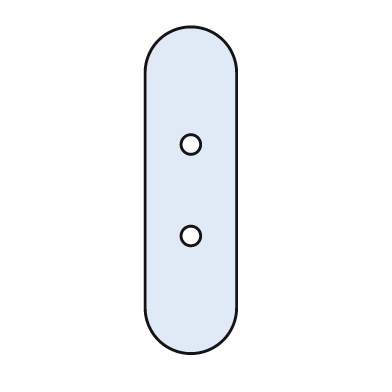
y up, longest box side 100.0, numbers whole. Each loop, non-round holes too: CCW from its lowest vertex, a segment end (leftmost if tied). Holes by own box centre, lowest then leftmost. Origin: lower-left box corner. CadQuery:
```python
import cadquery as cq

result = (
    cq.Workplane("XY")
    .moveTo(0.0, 14.0)
    .threePointArc((14.0, 0.0), (28.0, 14.0))
    .lineTo(28.0, 86.0)
    .threePointArc((14.0, 100.0), (0.0, 86.0))
    .close()
    .moveTo(14.0, 36.0)
    .circle(3.0)
    .moveTo(14.0, 64.0)
    .circle(3.0)
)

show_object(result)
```